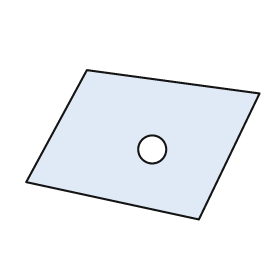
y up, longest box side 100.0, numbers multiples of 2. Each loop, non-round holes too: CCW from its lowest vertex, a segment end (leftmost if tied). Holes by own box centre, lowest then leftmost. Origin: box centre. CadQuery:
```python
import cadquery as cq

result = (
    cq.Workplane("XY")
    .moveTo(24.0, -32.0)
    .lineTo(50.0, 22.0)
    .lineTo(-24.0, 32.0)
    .lineTo(-50.0, -16.0)
    .close()
    .moveTo(4.0, -2.0)
    .circle(6.0)
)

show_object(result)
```